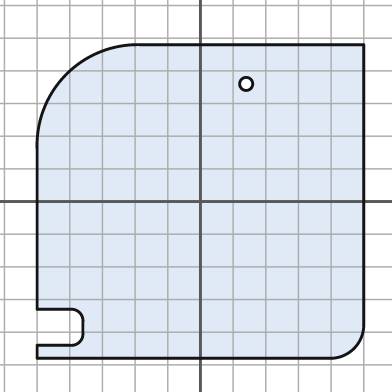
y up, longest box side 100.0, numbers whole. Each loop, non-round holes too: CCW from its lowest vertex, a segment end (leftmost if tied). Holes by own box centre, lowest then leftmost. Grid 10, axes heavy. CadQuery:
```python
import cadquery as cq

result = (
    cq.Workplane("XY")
    .moveTo(-50.0, -48.0)
    .lineTo(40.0, -48.0)
    .threePointArc((47.0, -45.0), (50.0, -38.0))
    .lineTo(50.0, 48.0)
    .lineTo(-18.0, 48.0)
    .threePointArc((-41.0, 39.0), (-50.0, 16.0))
    .lineTo(-50.0, -33.0)
    .lineTo(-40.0, -33.0)
    .threePointArc((-37.0, -34.0), (-36.0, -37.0))
    .lineTo(-36.0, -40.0)
    .threePointArc((-37.0, -43.0), (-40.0, -44.0))
    .lineTo(-50.0, -44.0)
    .close()
    .moveTo(14.0, 36.0)
    .circle(2.0)
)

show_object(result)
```